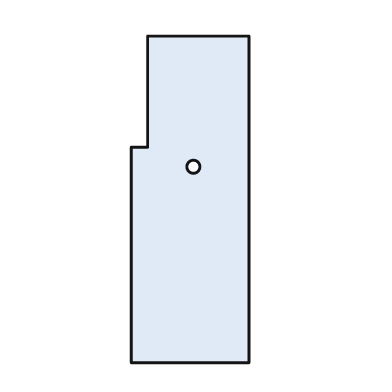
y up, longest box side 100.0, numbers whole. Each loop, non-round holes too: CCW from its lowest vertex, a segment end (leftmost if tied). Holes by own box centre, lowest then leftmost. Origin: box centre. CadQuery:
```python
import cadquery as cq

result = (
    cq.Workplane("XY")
    .moveTo(-18.0, -50.0)
    .lineTo(18.0, -50.0)
    .lineTo(18.0, 50.0)
    .lineTo(-13.0, 50.0)
    .lineTo(-13.0, 16.0)
    .lineTo(-18.0, 16.0)
    .close()
    .moveTo(1.0, 10.0)
    .circle(2.0)
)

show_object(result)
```